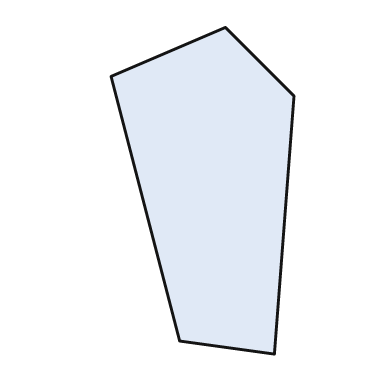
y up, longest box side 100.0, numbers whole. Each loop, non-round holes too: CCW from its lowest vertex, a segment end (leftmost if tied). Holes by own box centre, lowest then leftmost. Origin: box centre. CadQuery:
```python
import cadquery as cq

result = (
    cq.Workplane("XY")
    .moveTo(22.0, -50.0)
    .lineTo(28.0, 29.0)
    .lineTo(7.0, 50.0)
    .lineTo(-28.0, 35.0)
    .lineTo(-7.0, -46.0)
    .close()
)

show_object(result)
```